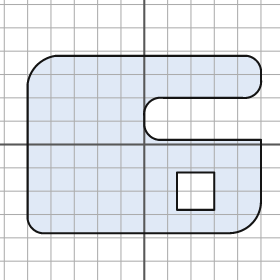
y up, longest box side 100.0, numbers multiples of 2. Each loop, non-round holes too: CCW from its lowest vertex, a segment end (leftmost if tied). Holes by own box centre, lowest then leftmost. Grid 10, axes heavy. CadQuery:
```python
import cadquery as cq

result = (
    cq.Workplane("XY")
    .moveTo(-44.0, -38.0)
    .lineTo(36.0, -38.0)
    .threePointArc((46.0, -34.0), (50.0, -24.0))
    .lineTo(50.0, 2.0)
    .lineTo(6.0, 2.0)
    .threePointArc((2.0, 4.0), (0.0, 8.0))
    .lineTo(0.0, 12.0)
    .threePointArc((2.0, 18.0), (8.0, 20.0))
    .lineTo(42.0, 20.0)
    .threePointArc((48.0, 22.0), (50.0, 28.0))
    .lineTo(50.0, 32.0)
    .threePointArc((48.0, 36.0), (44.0, 38.0))
    .lineTo(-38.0, 38.0)
    .threePointArc((-46.0, 34.0), (-50.0, 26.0))
    .lineTo(-50.0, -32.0)
    .threePointArc((-48.0, -36.0), (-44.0, -38.0))
    .close()
    .moveTo(14.0, -28.0)
    .lineTo(30.0, -28.0)
    .lineTo(30.0, -12.0)
    .lineTo(14.0, -12.0)
    .close()
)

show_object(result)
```